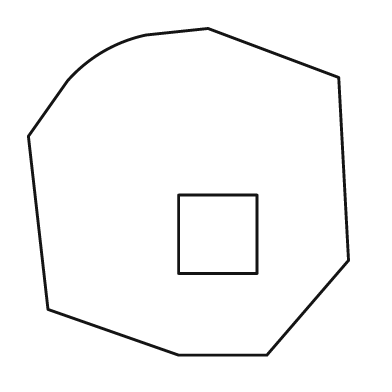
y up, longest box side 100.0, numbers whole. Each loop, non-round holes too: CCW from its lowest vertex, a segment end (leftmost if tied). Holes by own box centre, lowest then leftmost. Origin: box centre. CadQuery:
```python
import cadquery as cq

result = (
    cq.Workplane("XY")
    .moveTo(-3.0, -50.0)
    .lineTo(24.0, -50.0)
    .lineTo(49.0, -21.0)
    .lineTo(46.0, 35.0)
    .lineTo(6.0, 50.0)
    .lineTo(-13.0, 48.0)
    .threePointArc((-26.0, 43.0), (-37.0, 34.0))
    .lineTo(-49.0, 17.0)
    .lineTo(-43.0, -36.0)
    .close()
    .moveTo(-3.0, -25.0)
    .lineTo(21.0, -25.0)
    .lineTo(21.0, -1.0)
    .lineTo(-3.0, -1.0)
    .close()
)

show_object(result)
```